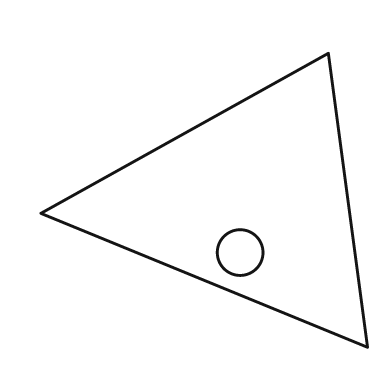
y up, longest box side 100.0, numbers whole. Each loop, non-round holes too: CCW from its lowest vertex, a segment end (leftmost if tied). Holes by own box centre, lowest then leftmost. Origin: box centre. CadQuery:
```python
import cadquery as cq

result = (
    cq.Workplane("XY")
    .moveTo(50.0, -45.0)
    .lineTo(38.0, 45.0)
    .lineTo(-50.0, -4.0)
    .close()
    .moveTo(11.0, -16.0)
    .circle(7.0)
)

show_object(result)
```